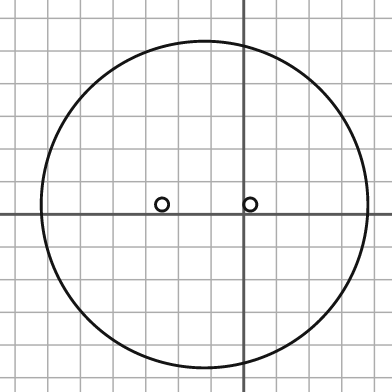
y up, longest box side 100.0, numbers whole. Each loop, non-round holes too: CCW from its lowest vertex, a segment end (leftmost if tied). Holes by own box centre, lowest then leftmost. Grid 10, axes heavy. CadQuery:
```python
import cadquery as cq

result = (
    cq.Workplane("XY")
    .moveTo(-12.0, 3.0)
    .circle(50.0)
    .moveTo(-25.0, 3.0)
    .circle(2.0)
    .moveTo(2.0, 3.0)
    .circle(2.0)
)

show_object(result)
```